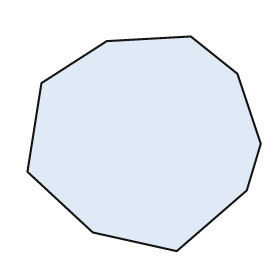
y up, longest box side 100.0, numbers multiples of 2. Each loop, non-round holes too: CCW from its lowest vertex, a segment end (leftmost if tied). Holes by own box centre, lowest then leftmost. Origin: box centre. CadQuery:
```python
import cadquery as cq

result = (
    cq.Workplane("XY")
    .moveTo(14.0, -46.0)
    .lineTo(44.0, -20.0)
    .lineTo(50.0, 0.0)
    .lineTo(40.0, 30.0)
    .lineTo(20.0, 46.0)
    .lineTo(-16.0, 44.0)
    .lineTo(-44.0, 26.0)
    .lineTo(-50.0, -12.0)
    .lineTo(-22.0, -38.0)
    .close()
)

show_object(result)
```